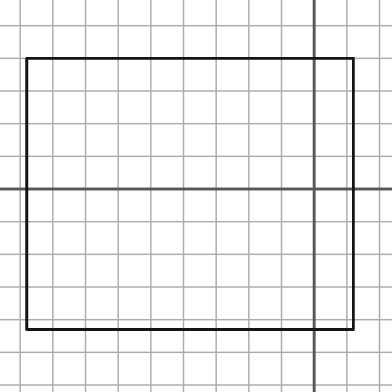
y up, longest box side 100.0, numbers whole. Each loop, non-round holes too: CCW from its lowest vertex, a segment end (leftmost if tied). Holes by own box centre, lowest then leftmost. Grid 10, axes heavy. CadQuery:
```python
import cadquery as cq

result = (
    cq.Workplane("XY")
    .moveTo(-88.0, -43.0)
    .lineTo(12.0, -43.0)
    .lineTo(12.0, 40.0)
    .lineTo(-88.0, 40.0)
    .close()
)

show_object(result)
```